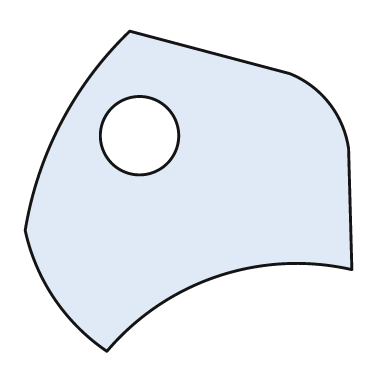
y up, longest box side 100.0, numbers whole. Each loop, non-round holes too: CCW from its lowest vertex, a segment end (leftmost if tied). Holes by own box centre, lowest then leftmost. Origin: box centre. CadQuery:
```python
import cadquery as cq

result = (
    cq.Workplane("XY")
    .moveTo(-25.0, -49.0)
    .threePointArc((9.0, -26.0), (50.0, -24.0))
    .lineTo(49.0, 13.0)
    .threePointArc((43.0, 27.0), (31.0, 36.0))
    .lineTo(-18.0, 49.0)
    .threePointArc((-39.0, 21.0), (-50.0, -12.0))
    .threePointArc((-41.0, -33.0), (-25.0, -49.0))
    .close()
    .moveTo(-15.0, 17.0)
    .circle(12.0)
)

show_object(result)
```